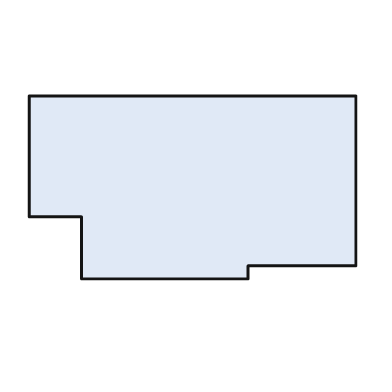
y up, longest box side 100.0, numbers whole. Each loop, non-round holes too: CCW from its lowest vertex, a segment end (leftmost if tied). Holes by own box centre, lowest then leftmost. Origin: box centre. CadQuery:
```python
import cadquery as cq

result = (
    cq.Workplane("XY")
    .moveTo(-34.0, -28.0)
    .lineTo(17.0, -28.0)
    .lineTo(17.0, -24.0)
    .lineTo(50.0, -24.0)
    .lineTo(50.0, 28.0)
    .lineTo(-50.0, 28.0)
    .lineTo(-50.0, -9.0)
    .lineTo(-34.0, -9.0)
    .close()
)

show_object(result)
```